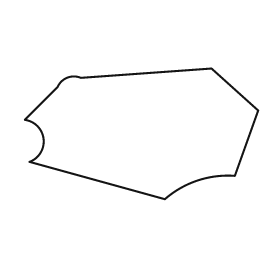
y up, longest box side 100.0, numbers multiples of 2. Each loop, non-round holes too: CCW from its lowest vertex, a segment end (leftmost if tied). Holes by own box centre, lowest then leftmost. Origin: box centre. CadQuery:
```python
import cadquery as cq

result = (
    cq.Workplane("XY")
    .moveTo(10.0, -28.0)
    .threePointArc((24.0, -20.0), (40.0, -18.0))
    .lineTo(50.0, 10.0)
    .lineTo(30.0, 28.0)
    .lineTo(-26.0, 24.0)
    .threePointArc((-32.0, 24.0), (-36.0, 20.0))
    .lineTo(-50.0, 6.0)
    .threePointArc((-42.0, -2.0), (-48.0, -12.0))
    .close()
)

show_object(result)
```